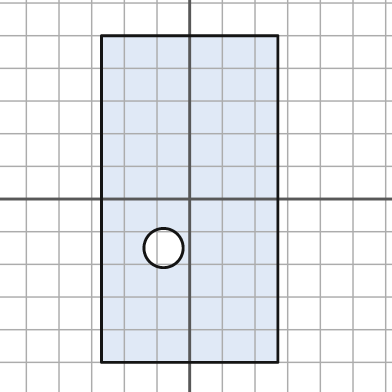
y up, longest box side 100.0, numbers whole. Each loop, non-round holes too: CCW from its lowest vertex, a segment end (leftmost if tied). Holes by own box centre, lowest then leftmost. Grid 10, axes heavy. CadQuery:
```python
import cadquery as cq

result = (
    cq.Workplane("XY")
    .moveTo(-27.0, -50.0)
    .lineTo(27.0, -50.0)
    .lineTo(27.0, 50.0)
    .lineTo(-27.0, 50.0)
    .close()
    .moveTo(-8.0, -15.0)
    .circle(6.0)
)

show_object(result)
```